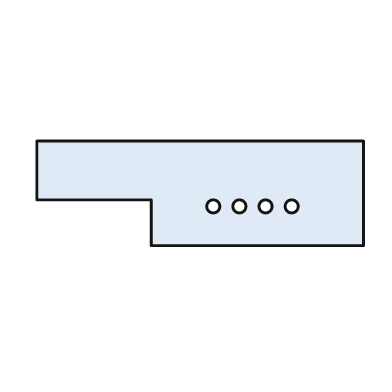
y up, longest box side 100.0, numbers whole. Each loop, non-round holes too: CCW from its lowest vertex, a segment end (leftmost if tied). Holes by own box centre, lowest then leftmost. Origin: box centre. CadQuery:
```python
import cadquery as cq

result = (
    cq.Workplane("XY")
    .moveTo(-15.0, -16.0)
    .lineTo(50.0, -16.0)
    .lineTo(50.0, 16.0)
    .lineTo(-50.0, 16.0)
    .lineTo(-50.0, -2.0)
    .lineTo(-15.0, -2.0)
    .close()
    .moveTo(4.0, -4.0)
    .circle(2.0)
    .moveTo(12.0, -4.0)
    .circle(2.0)
    .moveTo(20.0, -4.0)
    .circle(2.0)
    .moveTo(28.0, -4.0)
    .circle(2.0)
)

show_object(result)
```